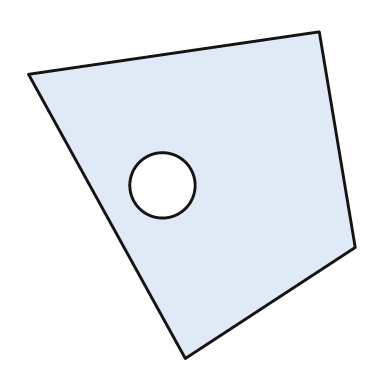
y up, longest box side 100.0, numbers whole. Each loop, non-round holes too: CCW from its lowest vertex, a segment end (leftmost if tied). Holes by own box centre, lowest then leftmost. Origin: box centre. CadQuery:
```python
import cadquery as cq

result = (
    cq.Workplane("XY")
    .moveTo(-2.0, -50.0)
    .lineTo(50.0, -16.0)
    .lineTo(39.0, 50.0)
    .lineTo(-50.0, 37.0)
    .close()
    .moveTo(-9.0, 3.0)
    .circle(10.0)
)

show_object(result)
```